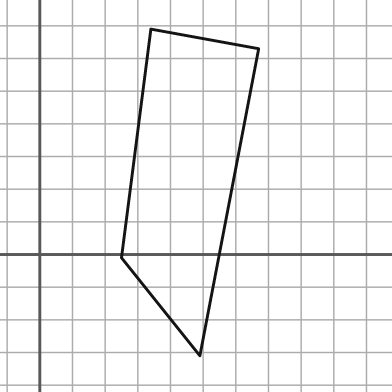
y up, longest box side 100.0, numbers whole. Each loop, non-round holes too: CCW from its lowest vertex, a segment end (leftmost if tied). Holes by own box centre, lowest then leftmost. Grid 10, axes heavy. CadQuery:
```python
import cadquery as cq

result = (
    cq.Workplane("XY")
    .moveTo(49.0, -31.0)
    .lineTo(67.0, 63.0)
    .lineTo(34.0, 69.0)
    .lineTo(25.0, -1.0)
    .close()
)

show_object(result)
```